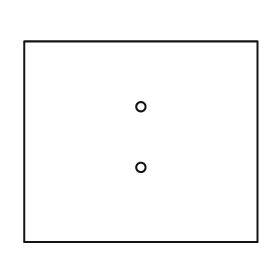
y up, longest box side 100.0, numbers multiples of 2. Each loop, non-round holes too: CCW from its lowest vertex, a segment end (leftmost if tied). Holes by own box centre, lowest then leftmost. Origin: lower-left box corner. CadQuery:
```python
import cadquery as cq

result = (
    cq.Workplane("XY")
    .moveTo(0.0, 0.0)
    .lineTo(100.0, 0.0)
    .lineTo(100.0, 86.0)
    .lineTo(0.0, 86.0)
    .close()
    .moveTo(50.0, 32.0)
    .circle(2.0)
    .moveTo(50.0, 58.0)
    .circle(2.0)
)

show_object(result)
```